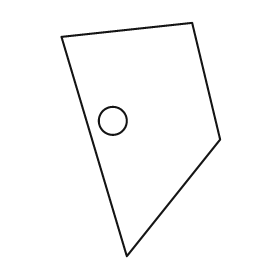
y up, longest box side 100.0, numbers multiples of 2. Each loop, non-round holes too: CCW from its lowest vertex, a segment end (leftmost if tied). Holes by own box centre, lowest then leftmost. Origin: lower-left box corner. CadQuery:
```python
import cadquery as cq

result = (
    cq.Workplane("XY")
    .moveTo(28.0, 0.0)
    .lineTo(68.0, 50.0)
    .lineTo(56.0, 100.0)
    .lineTo(0.0, 94.0)
    .close()
    .moveTo(22.0, 58.0)
    .circle(6.0)
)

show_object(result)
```